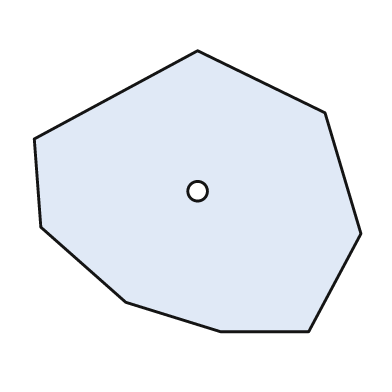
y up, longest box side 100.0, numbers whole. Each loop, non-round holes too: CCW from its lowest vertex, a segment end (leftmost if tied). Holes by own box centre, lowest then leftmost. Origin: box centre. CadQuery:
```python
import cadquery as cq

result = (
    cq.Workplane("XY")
    .moveTo(7.0, -43.0)
    .lineTo(34.0, -43.0)
    .lineTo(50.0, -13.0)
    .lineTo(39.0, 24.0)
    .lineTo(0.0, 43.0)
    .lineTo(-50.0, 16.0)
    .lineTo(-48.0, -11.0)
    .lineTo(-22.0, -34.0)
    .close()
    .moveTo(0.0, 0.0)
    .circle(3.0)
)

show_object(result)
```